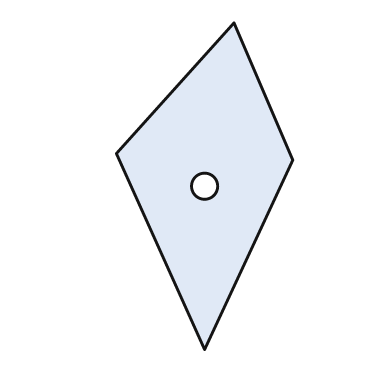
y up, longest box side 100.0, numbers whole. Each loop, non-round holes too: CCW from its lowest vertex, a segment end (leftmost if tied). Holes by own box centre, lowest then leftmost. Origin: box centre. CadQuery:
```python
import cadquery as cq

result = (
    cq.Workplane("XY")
    .moveTo(0.0, -50.0)
    .lineTo(27.0, 8.0)
    .lineTo(9.0, 50.0)
    .lineTo(-27.0, 10.0)
    .close()
    .moveTo(0.0, 0.0)
    .circle(4.0)
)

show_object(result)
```